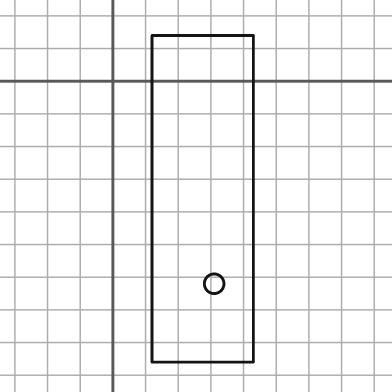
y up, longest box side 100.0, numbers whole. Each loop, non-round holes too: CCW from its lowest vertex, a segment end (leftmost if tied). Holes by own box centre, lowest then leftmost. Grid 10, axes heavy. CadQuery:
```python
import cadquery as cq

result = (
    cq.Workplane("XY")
    .moveTo(12.0, -86.0)
    .lineTo(43.0, -86.0)
    .lineTo(43.0, 14.0)
    .lineTo(12.0, 14.0)
    .close()
    .moveTo(31.0, -62.0)
    .circle(3.0)
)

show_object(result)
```